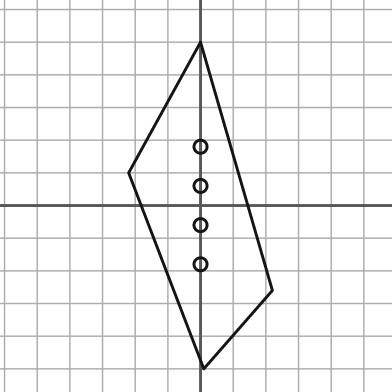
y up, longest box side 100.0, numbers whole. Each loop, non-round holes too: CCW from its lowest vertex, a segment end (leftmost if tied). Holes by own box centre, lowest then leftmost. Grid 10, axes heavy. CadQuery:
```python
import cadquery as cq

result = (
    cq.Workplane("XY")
    .moveTo(1.0, -50.0)
    .lineTo(22.0, -26.0)
    .lineTo(0.0, 50.0)
    .lineTo(-22.0, 10.0)
    .close()
    .moveTo(0.0, -18.0)
    .circle(2.0)
    .moveTo(0.0, -6.0)
    .circle(2.0)
    .moveTo(0.0, 6.0)
    .circle(2.0)
    .moveTo(0.0, 18.0)
    .circle(2.0)
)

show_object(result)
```